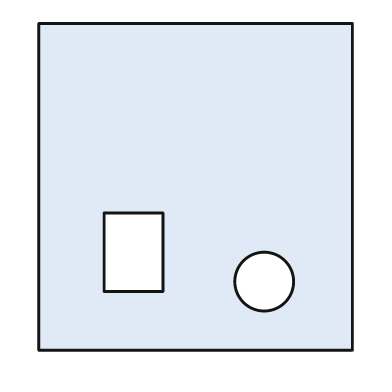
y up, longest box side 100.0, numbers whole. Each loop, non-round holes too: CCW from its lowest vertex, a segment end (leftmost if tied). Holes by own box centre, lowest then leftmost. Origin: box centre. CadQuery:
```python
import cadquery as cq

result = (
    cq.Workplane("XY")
    .moveTo(-48.0, -50.0)
    .lineTo(48.0, -50.0)
    .lineTo(48.0, 50.0)
    .lineTo(-48.0, 50.0)
    .close()
    .moveTo(21.0, -29.0)
    .circle(9.0)
    .moveTo(-28.0, -32.0)
    .lineTo(-10.0, -32.0)
    .lineTo(-10.0, -8.0)
    .lineTo(-28.0, -8.0)
    .close()
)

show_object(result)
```